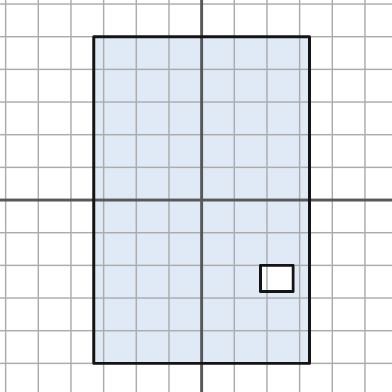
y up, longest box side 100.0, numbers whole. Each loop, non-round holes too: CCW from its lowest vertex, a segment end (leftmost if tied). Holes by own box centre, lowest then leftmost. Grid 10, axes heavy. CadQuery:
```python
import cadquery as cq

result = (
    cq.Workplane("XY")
    .moveTo(-33.0, -50.0)
    .lineTo(33.0, -50.0)
    .lineTo(33.0, 50.0)
    .lineTo(-33.0, 50.0)
    .close()
    .moveTo(18.0, -28.0)
    .lineTo(28.0, -28.0)
    .lineTo(28.0, -20.0)
    .lineTo(18.0, -20.0)
    .close()
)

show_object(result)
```